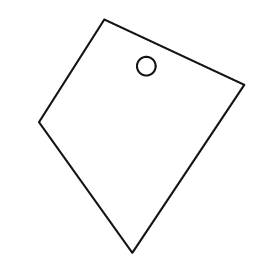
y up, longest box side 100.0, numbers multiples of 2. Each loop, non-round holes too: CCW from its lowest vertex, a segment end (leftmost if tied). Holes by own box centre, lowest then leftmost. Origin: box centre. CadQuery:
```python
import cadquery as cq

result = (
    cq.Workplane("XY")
    .moveTo(-4.0, -50.0)
    .lineTo(44.0, 22.0)
    .lineTo(-16.0, 50.0)
    .lineTo(-44.0, 6.0)
    .close()
    .moveTo(2.0, 30.0)
    .circle(4.0)
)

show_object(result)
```